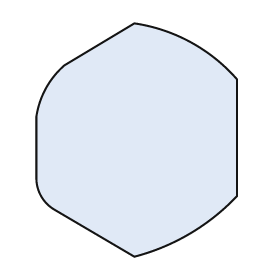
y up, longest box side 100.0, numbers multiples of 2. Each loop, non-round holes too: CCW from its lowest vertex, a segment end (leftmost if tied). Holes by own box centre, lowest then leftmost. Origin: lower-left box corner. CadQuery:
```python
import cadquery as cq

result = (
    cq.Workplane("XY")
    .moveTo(42.0, 0.0)
    .threePointArc((66.0, 10.0), (86.0, 26.0))
    .lineTo(86.0, 76.0)
    .threePointArc((66.0, 92.0), (42.0, 100.0))
    .lineTo(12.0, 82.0)
    .threePointArc((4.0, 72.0), (0.0, 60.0))
    .lineTo(0.0, 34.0)
    .threePointArc((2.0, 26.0), (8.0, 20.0))
    .close()
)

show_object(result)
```